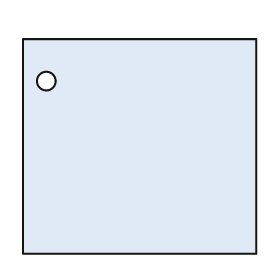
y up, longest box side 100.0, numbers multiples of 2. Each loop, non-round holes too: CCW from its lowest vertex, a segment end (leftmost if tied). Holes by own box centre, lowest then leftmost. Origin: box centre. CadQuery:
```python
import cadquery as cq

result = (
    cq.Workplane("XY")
    .moveTo(-50.0, -46.0)
    .lineTo(50.0, -46.0)
    .lineTo(50.0, 46.0)
    .lineTo(-50.0, 46.0)
    .close()
    .moveTo(-40.0, 28.0)
    .circle(4.0)
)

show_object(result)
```